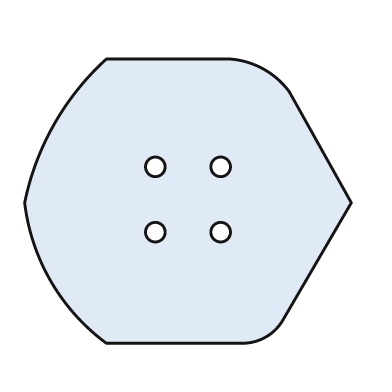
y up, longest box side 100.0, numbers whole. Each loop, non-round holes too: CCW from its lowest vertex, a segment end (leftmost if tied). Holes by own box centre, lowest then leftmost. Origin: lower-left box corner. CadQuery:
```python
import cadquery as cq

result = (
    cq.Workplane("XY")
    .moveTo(25.0, 0.0)
    .lineTo(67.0, 0.0)
    .threePointArc((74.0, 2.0), (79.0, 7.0))
    .lineTo(100.0, 43.0)
    .lineTo(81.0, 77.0)
    .threePointArc((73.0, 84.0), (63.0, 87.0))
    .lineTo(25.0, 87.0)
    .threePointArc((9.0, 67.0), (0.0, 43.0))
    .threePointArc((8.0, 19.0), (25.0, 0.0))
    .close()
    .moveTo(40.0, 34.0)
    .circle(3.0)
    .moveTo(60.0, 34.0)
    .circle(3.0)
    .moveTo(40.0, 54.0)
    .circle(3.0)
    .moveTo(60.0, 54.0)
    .circle(3.0)
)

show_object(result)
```